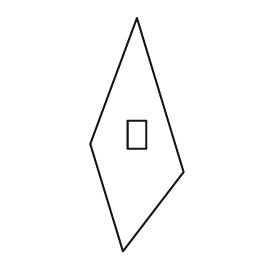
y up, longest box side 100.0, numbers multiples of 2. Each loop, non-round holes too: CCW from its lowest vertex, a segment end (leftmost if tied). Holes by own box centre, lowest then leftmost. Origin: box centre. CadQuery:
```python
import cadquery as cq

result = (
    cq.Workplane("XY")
    .moveTo(-6.0, -50.0)
    .lineTo(20.0, -16.0)
    .lineTo(0.0, 50.0)
    .lineTo(-20.0, -4.0)
    .close()
    .moveTo(-4.0, -6.0)
    .lineTo(4.0, -6.0)
    .lineTo(4.0, 6.0)
    .lineTo(-4.0, 6.0)
    .close()
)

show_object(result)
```